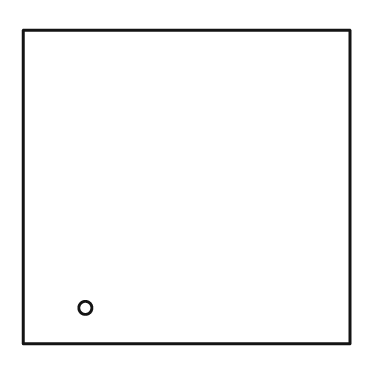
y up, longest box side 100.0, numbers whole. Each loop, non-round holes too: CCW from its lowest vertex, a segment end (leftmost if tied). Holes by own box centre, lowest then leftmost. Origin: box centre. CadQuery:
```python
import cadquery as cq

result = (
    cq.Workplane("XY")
    .moveTo(-50.0, -48.0)
    .lineTo(50.0, -48.0)
    .lineTo(50.0, 48.0)
    .lineTo(-50.0, 48.0)
    .close()
    .moveTo(-31.0, -37.0)
    .circle(2.0)
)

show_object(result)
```